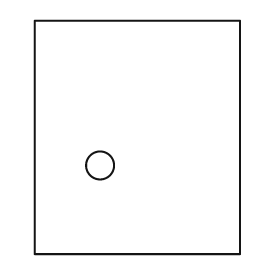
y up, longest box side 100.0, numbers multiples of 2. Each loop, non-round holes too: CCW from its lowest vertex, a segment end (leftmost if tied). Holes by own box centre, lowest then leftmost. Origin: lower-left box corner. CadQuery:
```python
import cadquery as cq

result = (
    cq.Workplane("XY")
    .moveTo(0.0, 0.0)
    .lineTo(88.0, 0.0)
    .lineTo(88.0, 100.0)
    .lineTo(0.0, 100.0)
    .close()
    .moveTo(28.0, 38.0)
    .circle(6.0)
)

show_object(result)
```